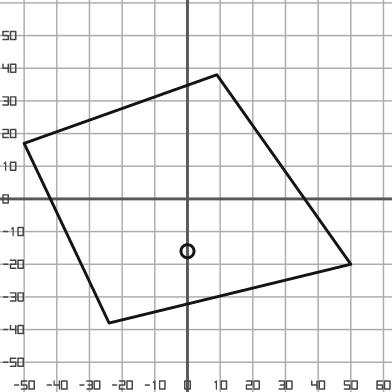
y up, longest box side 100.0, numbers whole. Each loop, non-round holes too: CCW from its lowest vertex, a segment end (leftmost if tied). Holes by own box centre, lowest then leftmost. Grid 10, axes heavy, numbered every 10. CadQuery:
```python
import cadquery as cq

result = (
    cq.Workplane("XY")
    .moveTo(-24.0, -38.0)
    .lineTo(50.0, -20.0)
    .lineTo(9.0, 38.0)
    .lineTo(-50.0, 17.0)
    .close()
    .moveTo(0.0, -16.0)
    .circle(2.0)
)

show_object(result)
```